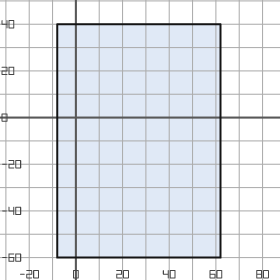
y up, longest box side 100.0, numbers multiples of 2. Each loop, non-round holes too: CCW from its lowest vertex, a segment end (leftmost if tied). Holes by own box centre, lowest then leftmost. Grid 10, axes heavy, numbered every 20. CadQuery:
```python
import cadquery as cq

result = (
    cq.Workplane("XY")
    .moveTo(-8.0, -60.0)
    .lineTo(62.0, -60.0)
    .lineTo(62.0, 40.0)
    .lineTo(-8.0, 40.0)
    .close()
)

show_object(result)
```